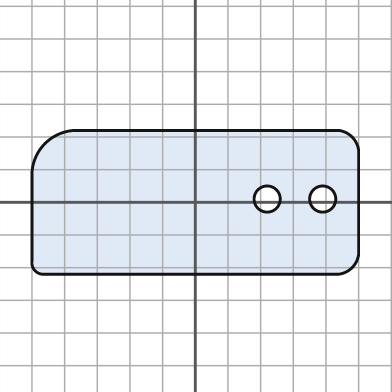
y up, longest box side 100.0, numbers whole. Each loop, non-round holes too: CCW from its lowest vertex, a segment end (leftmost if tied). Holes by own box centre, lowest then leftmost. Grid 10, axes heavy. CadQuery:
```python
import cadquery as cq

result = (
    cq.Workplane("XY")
    .moveTo(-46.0, -22.0)
    .lineTo(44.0, -22.0)
    .threePointArc((48.0, -20.0), (50.0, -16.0))
    .lineTo(50.0, 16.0)
    .threePointArc((48.0, 20.0), (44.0, 22.0))
    .lineTo(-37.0, 22.0)
    .threePointArc((-46.0, 18.0), (-50.0, 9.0))
    .lineTo(-50.0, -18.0)
    .threePointArc((-49.0, -21.0), (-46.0, -22.0))
    .close()
    .moveTo(22.0, 1.0)
    .circle(4.0)
    .moveTo(39.0, 1.0)
    .circle(4.0)
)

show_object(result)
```